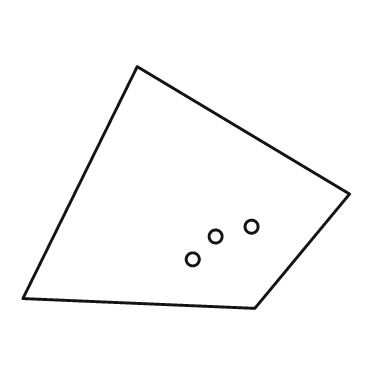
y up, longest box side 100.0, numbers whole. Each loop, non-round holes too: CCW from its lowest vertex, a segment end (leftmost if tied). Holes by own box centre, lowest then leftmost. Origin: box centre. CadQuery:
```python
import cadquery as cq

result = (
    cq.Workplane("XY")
    .moveTo(21.0, -37.0)
    .lineTo(50.0, -2.0)
    .lineTo(-15.0, 37.0)
    .lineTo(-50.0, -34.0)
    .close()
    .moveTo(2.0, -22.0)
    .circle(2.0)
    .moveTo(9.0, -15.0)
    .circle(2.0)
    .moveTo(20.0, -12.0)
    .circle(2.0)
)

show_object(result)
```